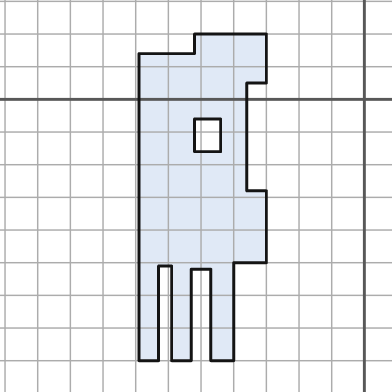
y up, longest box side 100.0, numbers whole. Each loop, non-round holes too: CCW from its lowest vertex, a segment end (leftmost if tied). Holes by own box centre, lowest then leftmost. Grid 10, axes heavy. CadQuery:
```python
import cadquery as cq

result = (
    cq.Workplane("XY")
    .moveTo(-69.0, -80.0)
    .lineTo(-63.0, -80.0)
    .lineTo(-63.0, -51.0)
    .lineTo(-59.0, -51.0)
    .lineTo(-59.0, -80.0)
    .lineTo(-53.0, -80.0)
    .lineTo(-53.0, -52.0)
    .lineTo(-47.0, -52.0)
    .lineTo(-47.0, -80.0)
    .lineTo(-40.0, -80.0)
    .lineTo(-40.0, -50.0)
    .lineTo(-30.0, -50.0)
    .lineTo(-30.0, -28.0)
    .lineTo(-36.0, -28.0)
    .lineTo(-36.0, 5.0)
    .lineTo(-30.0, 5.0)
    .lineTo(-30.0, 20.0)
    .lineTo(-52.0, 20.0)
    .lineTo(-52.0, 14.0)
    .lineTo(-69.0, 14.0)
    .close()
    .moveTo(-52.0, -16.0)
    .lineTo(-44.0, -16.0)
    .lineTo(-44.0, -6.0)
    .lineTo(-52.0, -6.0)
    .close()
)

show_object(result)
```